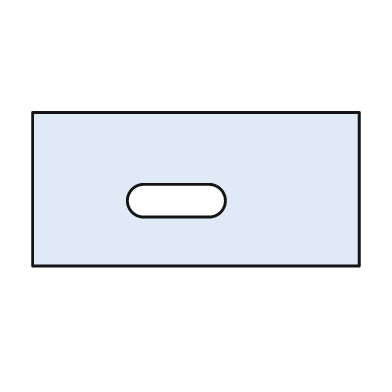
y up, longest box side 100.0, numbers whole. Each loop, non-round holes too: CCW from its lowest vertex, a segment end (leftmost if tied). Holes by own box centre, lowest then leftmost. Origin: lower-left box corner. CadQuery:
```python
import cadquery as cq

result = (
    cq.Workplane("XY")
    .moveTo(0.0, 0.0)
    .lineTo(100.0, 0.0)
    .lineTo(100.0, 47.0)
    .lineTo(0.0, 47.0)
    .close()
    .moveTo(34.0, 15.0)
    .lineTo(54.0, 15.0)
    .threePointArc((59.0, 20.0), (54.0, 25.0))
    .lineTo(34.0, 25.0)
    .threePointArc((29.0, 20.0), (34.0, 15.0))
    .close()
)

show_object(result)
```